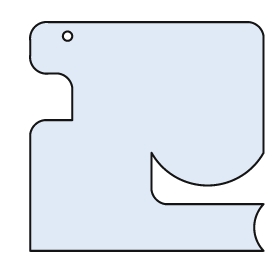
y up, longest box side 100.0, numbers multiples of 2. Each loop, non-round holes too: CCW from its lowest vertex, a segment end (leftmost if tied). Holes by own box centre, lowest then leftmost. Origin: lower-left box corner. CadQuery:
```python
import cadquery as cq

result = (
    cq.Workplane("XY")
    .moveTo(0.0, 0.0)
    .lineTo(100.0, 0.0)
    .threePointArc((96.0, 10.0), (100.0, 20.0))
    .lineTo(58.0, 20.0)
    .threePointArc((54.0, 22.0), (52.0, 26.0))
    .lineTo(52.0, 42.0)
    .threePointArc((76.0, 28.0), (100.0, 42.0))
    .lineTo(100.0, 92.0)
    .threePointArc((98.0, 96.0), (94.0, 98.0))
    .lineTo(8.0, 98.0)
    .threePointArc((2.0, 96.0), (0.0, 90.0))
    .lineTo(0.0, 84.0)
    .threePointArc((2.0, 78.0), (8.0, 76.0))
    .lineTo(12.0, 76.0)
    .threePointArc((16.0, 74.0), (18.0, 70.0))
    .lineTo(18.0, 56.0)
    .lineTo(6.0, 56.0)
    .threePointArc((2.0, 54.0), (0.0, 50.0))
    .close()
    .moveTo(16.0, 92.0)
    .circle(2.0)
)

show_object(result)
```